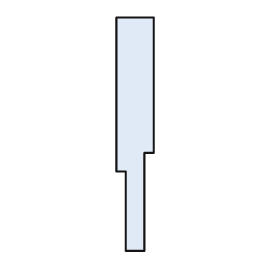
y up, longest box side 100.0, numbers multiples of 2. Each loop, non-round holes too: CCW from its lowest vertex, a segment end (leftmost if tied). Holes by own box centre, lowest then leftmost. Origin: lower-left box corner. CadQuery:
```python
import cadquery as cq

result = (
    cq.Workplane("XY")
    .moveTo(4.0, 0.0)
    .lineTo(12.0, 0.0)
    .lineTo(12.0, 42.0)
    .lineTo(16.0, 42.0)
    .lineTo(16.0, 100.0)
    .lineTo(0.0, 100.0)
    .lineTo(0.0, 34.0)
    .lineTo(4.0, 34.0)
    .close()
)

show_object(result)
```